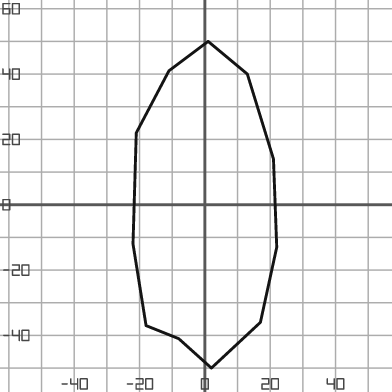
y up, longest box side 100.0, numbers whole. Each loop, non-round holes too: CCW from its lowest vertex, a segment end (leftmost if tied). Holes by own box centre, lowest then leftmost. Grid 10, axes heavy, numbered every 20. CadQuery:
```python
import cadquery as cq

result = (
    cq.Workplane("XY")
    .moveTo(2.0, -50.0)
    .lineTo(17.0, -36.0)
    .lineTo(22.0, -13.0)
    .lineTo(21.0, 14.0)
    .lineTo(13.0, 40.0)
    .lineTo(1.0, 50.0)
    .lineTo(-11.0, 41.0)
    .lineTo(-21.0, 22.0)
    .lineTo(-22.0, -12.0)
    .lineTo(-18.0, -37.0)
    .lineTo(-8.0, -41.0)
    .close()
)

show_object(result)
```